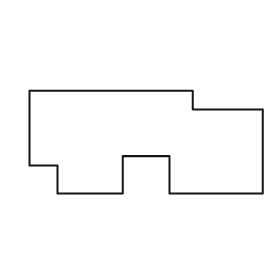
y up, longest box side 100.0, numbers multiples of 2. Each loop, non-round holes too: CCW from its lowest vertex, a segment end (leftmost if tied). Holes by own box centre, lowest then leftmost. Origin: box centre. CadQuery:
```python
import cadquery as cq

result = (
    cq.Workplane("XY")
    .moveTo(-38.0, -22.0)
    .lineTo(-10.0, -22.0)
    .lineTo(-10.0, -6.0)
    .lineTo(10.0, -6.0)
    .lineTo(10.0, -22.0)
    .lineTo(50.0, -22.0)
    .lineTo(50.0, 14.0)
    .lineTo(20.0, 14.0)
    .lineTo(20.0, 22.0)
    .lineTo(-50.0, 22.0)
    .lineTo(-50.0, -10.0)
    .lineTo(-38.0, -10.0)
    .close()
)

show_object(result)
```